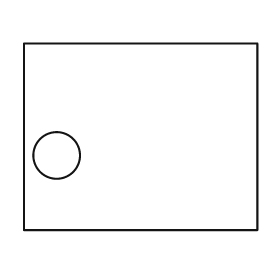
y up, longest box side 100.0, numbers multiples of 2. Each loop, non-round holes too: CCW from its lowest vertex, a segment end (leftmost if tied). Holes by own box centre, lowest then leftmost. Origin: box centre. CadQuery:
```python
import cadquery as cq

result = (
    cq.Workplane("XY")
    .moveTo(-50.0, -40.0)
    .lineTo(50.0, -40.0)
    .lineTo(50.0, 40.0)
    .lineTo(-50.0, 40.0)
    .close()
    .moveTo(-36.0, -8.0)
    .circle(10.0)
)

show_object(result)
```